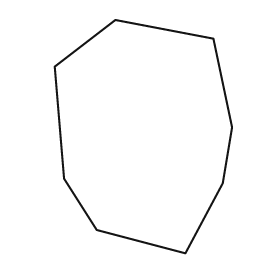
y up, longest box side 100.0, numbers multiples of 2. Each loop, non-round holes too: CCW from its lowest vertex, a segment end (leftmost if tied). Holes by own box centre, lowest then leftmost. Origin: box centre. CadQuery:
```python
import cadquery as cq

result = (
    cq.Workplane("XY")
    .moveTo(18.0, -50.0)
    .lineTo(34.0, -20.0)
    .lineTo(38.0, 4.0)
    .lineTo(30.0, 42.0)
    .lineTo(-12.0, 50.0)
    .lineTo(-38.0, 30.0)
    .lineTo(-34.0, -18.0)
    .lineTo(-20.0, -40.0)
    .close()
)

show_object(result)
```